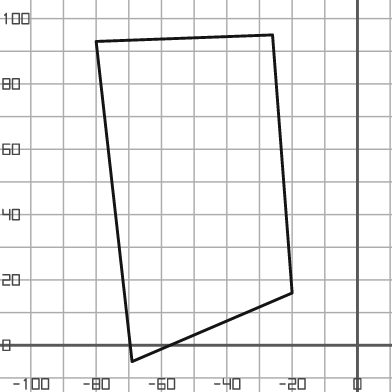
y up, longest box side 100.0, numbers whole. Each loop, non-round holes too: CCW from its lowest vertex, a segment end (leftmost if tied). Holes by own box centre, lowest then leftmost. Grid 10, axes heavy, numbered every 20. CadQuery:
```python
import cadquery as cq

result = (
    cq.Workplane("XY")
    .moveTo(-69.0, -5.0)
    .lineTo(-20.0, 16.0)
    .lineTo(-26.0, 95.0)
    .lineTo(-80.0, 93.0)
    .close()
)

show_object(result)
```